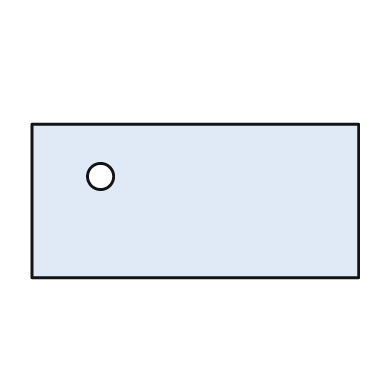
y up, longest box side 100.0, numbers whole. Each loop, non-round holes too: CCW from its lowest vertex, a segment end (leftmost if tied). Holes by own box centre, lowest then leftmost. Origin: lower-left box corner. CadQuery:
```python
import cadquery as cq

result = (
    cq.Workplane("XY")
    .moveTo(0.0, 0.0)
    .lineTo(100.0, 0.0)
    .lineTo(100.0, 47.0)
    .lineTo(0.0, 47.0)
    .close()
    .moveTo(21.0, 31.0)
    .circle(4.0)
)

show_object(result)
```